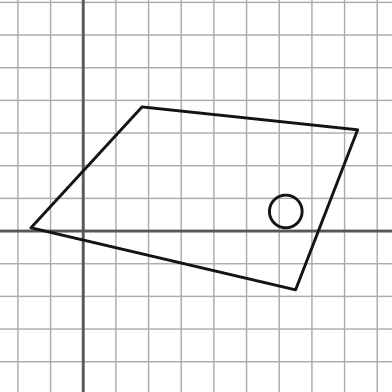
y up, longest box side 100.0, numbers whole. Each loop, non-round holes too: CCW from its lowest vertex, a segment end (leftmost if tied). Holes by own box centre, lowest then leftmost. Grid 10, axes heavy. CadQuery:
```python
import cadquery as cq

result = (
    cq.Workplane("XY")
    .moveTo(65.0, -18.0)
    .lineTo(84.0, 31.0)
    .lineTo(18.0, 38.0)
    .lineTo(-16.0, 1.0)
    .close()
    .moveTo(62.0, 6.0)
    .circle(5.0)
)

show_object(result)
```